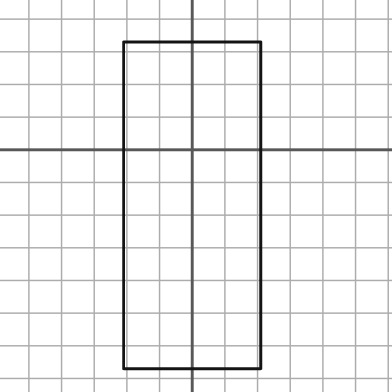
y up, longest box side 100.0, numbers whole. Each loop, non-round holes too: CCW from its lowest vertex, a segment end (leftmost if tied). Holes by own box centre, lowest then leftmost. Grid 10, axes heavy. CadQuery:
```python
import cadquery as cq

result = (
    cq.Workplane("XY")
    .moveTo(-21.0, -67.0)
    .lineTo(21.0, -67.0)
    .lineTo(21.0, 33.0)
    .lineTo(-21.0, 33.0)
    .close()
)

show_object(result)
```